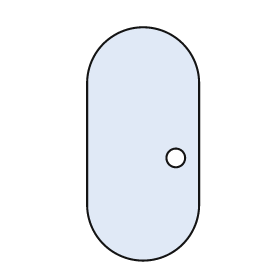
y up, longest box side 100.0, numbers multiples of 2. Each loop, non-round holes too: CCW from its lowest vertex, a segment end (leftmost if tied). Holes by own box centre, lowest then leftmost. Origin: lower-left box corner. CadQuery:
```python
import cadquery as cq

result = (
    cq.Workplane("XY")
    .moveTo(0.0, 24.0)
    .threePointArc((24.0, 0.0), (48.0, 24.0))
    .lineTo(48.0, 76.0)
    .threePointArc((24.0, 100.0), (0.0, 76.0))
    .close()
    .moveTo(38.0, 44.0)
    .circle(4.0)
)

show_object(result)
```